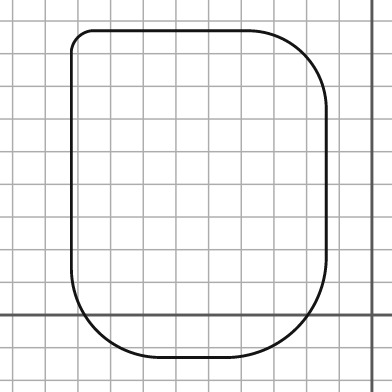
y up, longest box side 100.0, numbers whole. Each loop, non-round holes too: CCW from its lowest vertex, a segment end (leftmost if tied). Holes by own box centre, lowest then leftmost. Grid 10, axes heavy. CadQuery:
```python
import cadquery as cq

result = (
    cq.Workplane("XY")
    .moveTo(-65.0, -13.0)
    .lineTo(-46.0, -13.0)
    .threePointArc((-23.0, -4.0), (-14.0, 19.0))
    .lineTo(-14.0, 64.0)
    .threePointArc((-21.0, 80.0), (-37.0, 87.0))
    .lineTo(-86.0, 87.0)
    .threePointArc((-90.0, 85.0), (-92.0, 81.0))
    .lineTo(-92.0, 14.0)
    .threePointArc((-84.0, -5.0), (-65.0, -13.0))
    .close()
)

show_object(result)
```